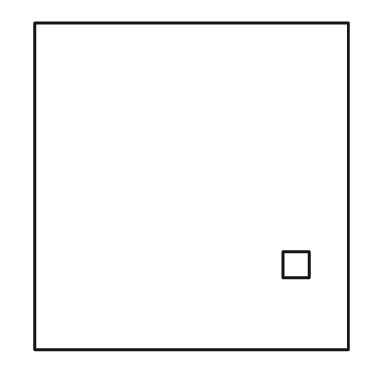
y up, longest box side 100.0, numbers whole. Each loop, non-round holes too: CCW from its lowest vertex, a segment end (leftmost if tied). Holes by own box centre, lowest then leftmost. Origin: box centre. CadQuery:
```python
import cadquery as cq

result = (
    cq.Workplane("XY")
    .moveTo(-48.0, -50.0)
    .lineTo(48.0, -50.0)
    .lineTo(48.0, 50.0)
    .lineTo(-48.0, 50.0)
    .close()
    .moveTo(28.0, -28.0)
    .lineTo(36.0, -28.0)
    .lineTo(36.0, -20.0)
    .lineTo(28.0, -20.0)
    .close()
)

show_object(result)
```